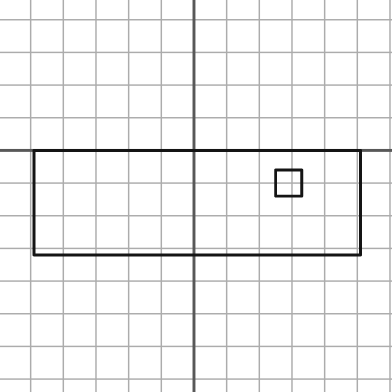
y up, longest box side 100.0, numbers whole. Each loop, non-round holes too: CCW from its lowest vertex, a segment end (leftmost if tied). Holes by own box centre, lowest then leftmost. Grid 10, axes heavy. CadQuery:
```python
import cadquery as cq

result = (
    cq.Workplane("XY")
    .moveTo(-49.0, -32.0)
    .lineTo(51.0, -32.0)
    .lineTo(51.0, 0.0)
    .lineTo(-49.0, 0.0)
    .close()
    .moveTo(25.0, -14.0)
    .lineTo(33.0, -14.0)
    .lineTo(33.0, -6.0)
    .lineTo(25.0, -6.0)
    .close()
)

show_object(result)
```